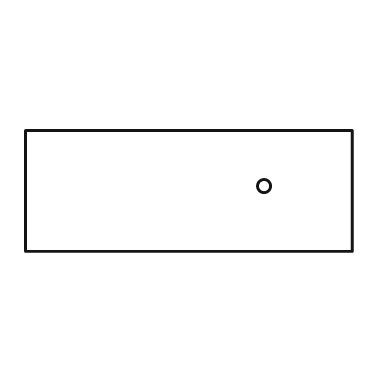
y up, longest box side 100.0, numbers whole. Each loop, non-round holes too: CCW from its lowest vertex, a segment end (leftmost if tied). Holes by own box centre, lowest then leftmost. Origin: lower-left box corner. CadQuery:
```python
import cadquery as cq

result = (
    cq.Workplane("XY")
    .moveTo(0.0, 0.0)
    .lineTo(100.0, 0.0)
    .lineTo(100.0, 37.0)
    .lineTo(0.0, 37.0)
    .close()
    .moveTo(73.0, 20.0)
    .circle(2.0)
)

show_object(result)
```